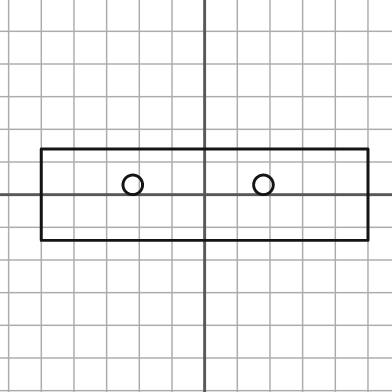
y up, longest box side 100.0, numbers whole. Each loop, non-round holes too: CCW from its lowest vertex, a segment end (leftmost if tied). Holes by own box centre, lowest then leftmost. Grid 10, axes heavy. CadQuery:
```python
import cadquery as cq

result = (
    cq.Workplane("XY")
    .moveTo(-50.0, -14.0)
    .lineTo(50.0, -14.0)
    .lineTo(50.0, 14.0)
    .lineTo(-50.0, 14.0)
    .close()
    .moveTo(-22.0, 3.0)
    .circle(3.0)
    .moveTo(18.0, 3.0)
    .circle(3.0)
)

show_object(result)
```